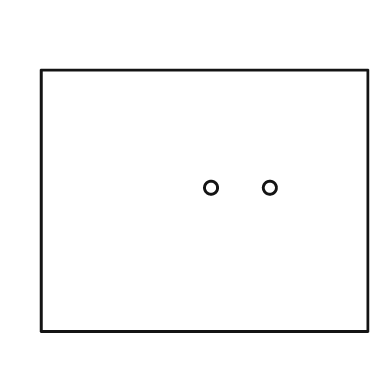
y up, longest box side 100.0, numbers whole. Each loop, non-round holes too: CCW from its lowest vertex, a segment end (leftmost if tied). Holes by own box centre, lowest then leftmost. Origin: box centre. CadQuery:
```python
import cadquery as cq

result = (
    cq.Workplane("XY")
    .moveTo(-50.0, -40.0)
    .lineTo(50.0, -40.0)
    .lineTo(50.0, 40.0)
    .lineTo(-50.0, 40.0)
    .close()
    .moveTo(2.0, 4.0)
    .circle(2.0)
    .moveTo(20.0, 4.0)
    .circle(2.0)
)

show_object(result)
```